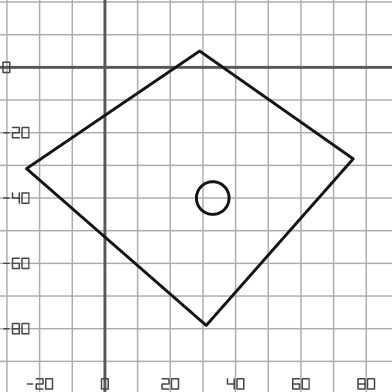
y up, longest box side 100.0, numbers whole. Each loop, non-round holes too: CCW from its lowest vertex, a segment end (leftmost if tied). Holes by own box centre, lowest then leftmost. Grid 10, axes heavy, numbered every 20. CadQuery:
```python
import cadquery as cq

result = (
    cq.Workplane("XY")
    .moveTo(31.0, -79.0)
    .lineTo(76.0, -28.0)
    .lineTo(29.0, 5.0)
    .lineTo(-24.0, -31.0)
    .close()
    .moveTo(33.0, -40.0)
    .circle(5.0)
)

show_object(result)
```